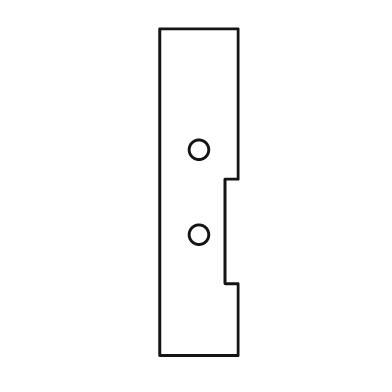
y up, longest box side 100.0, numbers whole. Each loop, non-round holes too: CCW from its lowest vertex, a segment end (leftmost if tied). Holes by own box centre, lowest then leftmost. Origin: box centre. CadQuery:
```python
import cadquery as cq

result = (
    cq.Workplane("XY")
    .moveTo(-12.0, -50.0)
    .lineTo(12.0, -50.0)
    .lineTo(12.0, -28.0)
    .lineTo(8.0, -28.0)
    .lineTo(8.0, 4.0)
    .lineTo(12.0, 4.0)
    .lineTo(12.0, 50.0)
    .lineTo(-12.0, 50.0)
    .close()
    .moveTo(0.0, -13.0)
    .circle(3.0)
    .moveTo(0.0, 13.0)
    .circle(3.0)
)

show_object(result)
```